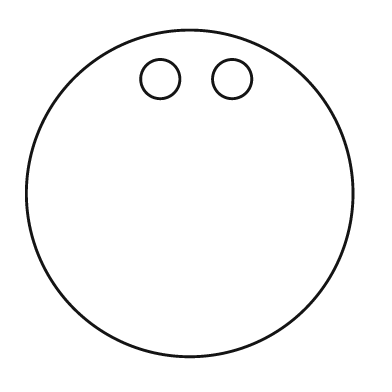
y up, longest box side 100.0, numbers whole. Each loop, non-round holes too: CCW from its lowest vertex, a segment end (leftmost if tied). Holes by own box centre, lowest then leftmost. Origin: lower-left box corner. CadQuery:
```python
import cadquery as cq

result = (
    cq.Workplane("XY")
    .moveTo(50.0, 50.0)
    .circle(50.0)
    .moveTo(41.0, 85.0)
    .circle(6.0)
    .moveTo(63.0, 85.0)
    .circle(6.0)
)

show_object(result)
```